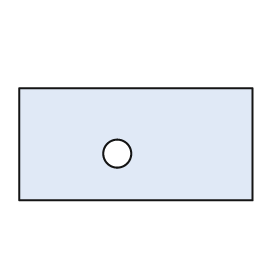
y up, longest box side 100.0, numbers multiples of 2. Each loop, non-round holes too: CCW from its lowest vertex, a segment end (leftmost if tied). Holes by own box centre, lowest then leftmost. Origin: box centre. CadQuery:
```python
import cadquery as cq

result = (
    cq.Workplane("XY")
    .moveTo(-50.0, -24.0)
    .lineTo(50.0, -24.0)
    .lineTo(50.0, 24.0)
    .lineTo(-50.0, 24.0)
    .close()
    .moveTo(-8.0, -4.0)
    .circle(6.0)
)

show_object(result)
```